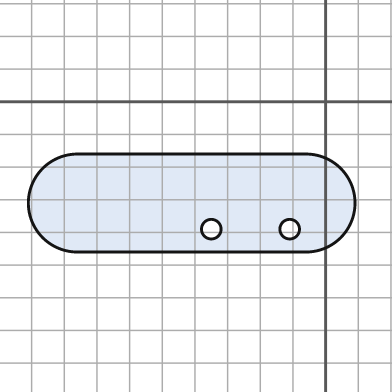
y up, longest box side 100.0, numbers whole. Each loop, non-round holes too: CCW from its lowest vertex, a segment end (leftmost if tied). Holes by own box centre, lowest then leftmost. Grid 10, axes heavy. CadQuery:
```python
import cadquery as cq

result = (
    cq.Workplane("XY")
    .moveTo(-76.0, -46.0)
    .lineTo(-6.0, -46.0)
    .threePointArc((9.0, -31.0), (-6.0, -16.0))
    .lineTo(-76.0, -16.0)
    .threePointArc((-91.0, -31.0), (-76.0, -46.0))
    .close()
    .moveTo(-35.0, -39.0)
    .circle(3.0)
    .moveTo(-11.0, -39.0)
    .circle(3.0)
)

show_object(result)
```